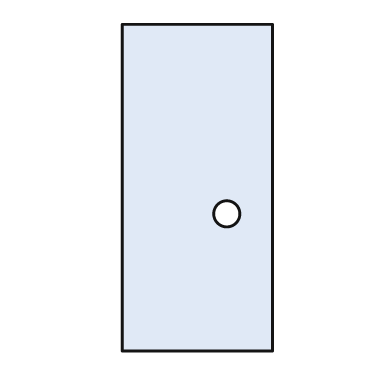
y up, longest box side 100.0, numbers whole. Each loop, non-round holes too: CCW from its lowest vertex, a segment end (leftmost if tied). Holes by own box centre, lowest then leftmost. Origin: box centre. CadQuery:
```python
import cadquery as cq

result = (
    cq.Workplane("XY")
    .moveTo(-23.0, -50.0)
    .lineTo(23.0, -50.0)
    .lineTo(23.0, 50.0)
    .lineTo(-23.0, 50.0)
    .close()
    .moveTo(9.0, -8.0)
    .circle(4.0)
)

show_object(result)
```